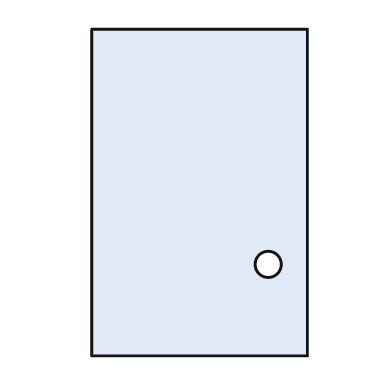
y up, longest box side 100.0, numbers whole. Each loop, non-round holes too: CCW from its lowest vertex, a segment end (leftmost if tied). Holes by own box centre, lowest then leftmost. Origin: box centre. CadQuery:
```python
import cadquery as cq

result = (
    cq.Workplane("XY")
    .moveTo(-33.0, -50.0)
    .lineTo(33.0, -50.0)
    .lineTo(33.0, 50.0)
    .lineTo(-33.0, 50.0)
    .close()
    .moveTo(21.0, -22.0)
    .circle(4.0)
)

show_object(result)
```